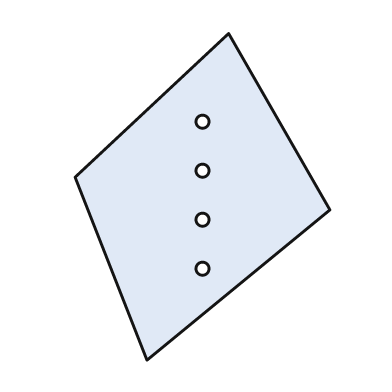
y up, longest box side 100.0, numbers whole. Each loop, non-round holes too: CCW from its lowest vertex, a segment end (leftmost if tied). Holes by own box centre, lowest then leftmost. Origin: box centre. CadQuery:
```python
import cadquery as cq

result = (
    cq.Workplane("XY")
    .moveTo(-17.0, -50.0)
    .lineTo(39.0, -4.0)
    .lineTo(8.0, 50.0)
    .lineTo(-39.0, 6.0)
    .close()
    .moveTo(0.0, -22.0)
    .circle(2.0)
    .moveTo(0.0, -7.0)
    .circle(2.0)
    .moveTo(0.0, 8.0)
    .circle(2.0)
    .moveTo(0.0, 23.0)
    .circle(2.0)
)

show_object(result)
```